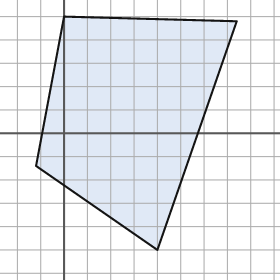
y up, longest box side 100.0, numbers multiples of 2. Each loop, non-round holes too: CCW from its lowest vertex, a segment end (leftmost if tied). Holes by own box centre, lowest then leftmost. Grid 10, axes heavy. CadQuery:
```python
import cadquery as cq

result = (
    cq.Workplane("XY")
    .moveTo(40.0, -50.0)
    .lineTo(74.0, 48.0)
    .lineTo(0.0, 50.0)
    .lineTo(-12.0, -14.0)
    .close()
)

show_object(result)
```